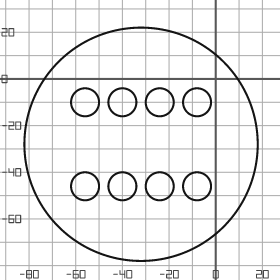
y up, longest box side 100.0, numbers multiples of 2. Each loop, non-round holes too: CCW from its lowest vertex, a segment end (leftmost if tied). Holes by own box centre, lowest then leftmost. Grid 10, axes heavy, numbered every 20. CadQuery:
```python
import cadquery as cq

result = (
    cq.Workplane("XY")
    .moveTo(-32.0, -28.0)
    .circle(50.0)
    .moveTo(-56.0, -46.0)
    .circle(6.0)
    .moveTo(-40.0, -46.0)
    .circle(6.0)
    .moveTo(-24.0, -46.0)
    .circle(6.0)
    .moveTo(-8.0, -46.0)
    .circle(6.0)
    .moveTo(-56.0, -10.0)
    .circle(6.0)
    .moveTo(-40.0, -10.0)
    .circle(6.0)
    .moveTo(-24.0, -10.0)
    .circle(6.0)
    .moveTo(-8.0, -10.0)
    .circle(6.0)
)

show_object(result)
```